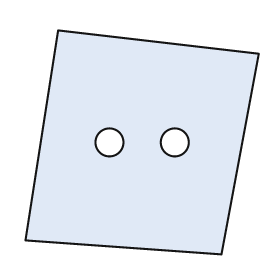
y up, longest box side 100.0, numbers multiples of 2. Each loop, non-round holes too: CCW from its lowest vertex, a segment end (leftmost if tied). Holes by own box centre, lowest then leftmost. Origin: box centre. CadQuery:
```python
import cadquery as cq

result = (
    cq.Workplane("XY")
    .moveTo(34.0, -48.0)
    .lineTo(50.0, 38.0)
    .lineTo(-36.0, 48.0)
    .lineTo(-50.0, -42.0)
    .close()
    .moveTo(-14.0, 0.0)
    .circle(6.0)
    .moveTo(14.0, 0.0)
    .circle(6.0)
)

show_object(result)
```